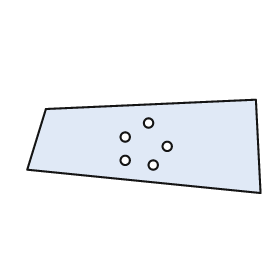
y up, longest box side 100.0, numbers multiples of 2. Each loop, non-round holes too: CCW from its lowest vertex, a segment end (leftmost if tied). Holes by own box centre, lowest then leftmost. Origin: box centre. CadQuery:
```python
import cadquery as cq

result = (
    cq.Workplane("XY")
    .moveTo(50.0, -20.0)
    .lineTo(48.0, 20.0)
    .lineTo(-42.0, 16.0)
    .lineTo(-50.0, -10.0)
    .close()
    .moveTo(4.0, -8.0)
    .circle(2.0)
    .moveTo(-8.0, -6.0)
    .circle(2.0)
    .moveTo(10.0, 0.0)
    .circle(2.0)
    .moveTo(-8.0, 4.0)
    .circle(2.0)
    .moveTo(2.0, 10.0)
    .circle(2.0)
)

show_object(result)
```